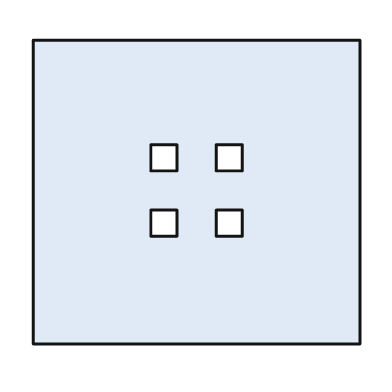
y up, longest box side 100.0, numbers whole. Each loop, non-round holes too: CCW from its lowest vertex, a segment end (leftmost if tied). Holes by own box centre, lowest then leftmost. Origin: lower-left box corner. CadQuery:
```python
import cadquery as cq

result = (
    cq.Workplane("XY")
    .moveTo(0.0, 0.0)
    .lineTo(100.0, 0.0)
    .lineTo(100.0, 93.0)
    .lineTo(0.0, 93.0)
    .close()
    .moveTo(36.0, 33.0)
    .lineTo(44.0, 33.0)
    .lineTo(44.0, 41.0)
    .lineTo(36.0, 41.0)
    .close()
    .moveTo(56.0, 33.0)
    .lineTo(64.0, 33.0)
    .lineTo(64.0, 41.0)
    .lineTo(56.0, 41.0)
    .close()
    .moveTo(36.0, 53.0)
    .lineTo(44.0, 53.0)
    .lineTo(44.0, 61.0)
    .lineTo(36.0, 61.0)
    .close()
    .moveTo(56.0, 53.0)
    .lineTo(64.0, 53.0)
    .lineTo(64.0, 61.0)
    .lineTo(56.0, 61.0)
    .close()
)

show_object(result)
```